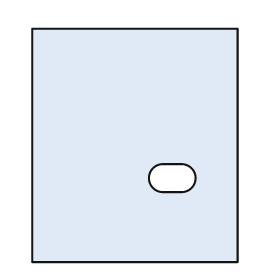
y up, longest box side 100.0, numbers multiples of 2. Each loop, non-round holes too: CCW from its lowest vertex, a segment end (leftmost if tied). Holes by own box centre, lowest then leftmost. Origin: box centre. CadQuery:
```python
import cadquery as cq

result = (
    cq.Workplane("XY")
    .moveTo(-44.0, -50.0)
    .lineTo(44.0, -50.0)
    .lineTo(44.0, 50.0)
    .lineTo(-44.0, 50.0)
    .close()
    .moveTo(12.0, -20.0)
    .lineTo(20.0, -20.0)
    .threePointArc((26.0, -14.0), (20.0, -8.0))
    .lineTo(12.0, -8.0)
    .threePointArc((6.0, -14.0), (12.0, -20.0))
    .close()
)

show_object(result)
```